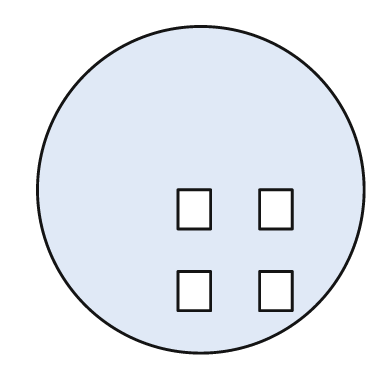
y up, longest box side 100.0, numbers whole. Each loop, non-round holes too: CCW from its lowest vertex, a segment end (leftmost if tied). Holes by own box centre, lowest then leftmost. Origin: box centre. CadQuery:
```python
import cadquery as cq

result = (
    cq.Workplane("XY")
    .moveTo(0.0, 0.0)
    .circle(50.0)
    .moveTo(-7.0, -37.0)
    .lineTo(3.0, -37.0)
    .lineTo(3.0, -25.0)
    .lineTo(-7.0, -25.0)
    .close()
    .moveTo(18.0, -37.0)
    .lineTo(28.0, -37.0)
    .lineTo(28.0, -25.0)
    .lineTo(18.0, -25.0)
    .close()
    .moveTo(-7.0, -12.0)
    .lineTo(3.0, -12.0)
    .lineTo(3.0, 0.0)
    .lineTo(-7.0, 0.0)
    .close()
    .moveTo(18.0, -12.0)
    .lineTo(28.0, -12.0)
    .lineTo(28.0, 0.0)
    .lineTo(18.0, 0.0)
    .close()
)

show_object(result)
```